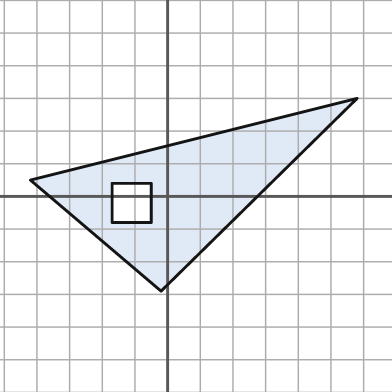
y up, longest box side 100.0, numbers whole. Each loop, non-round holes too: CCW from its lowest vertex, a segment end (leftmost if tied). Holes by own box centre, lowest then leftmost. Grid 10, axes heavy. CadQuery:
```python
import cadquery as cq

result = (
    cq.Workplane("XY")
    .moveTo(-2.0, -29.0)
    .lineTo(58.0, 30.0)
    .lineTo(-42.0, 5.0)
    .close()
    .moveTo(-17.0, -8.0)
    .lineTo(-5.0, -8.0)
    .lineTo(-5.0, 4.0)
    .lineTo(-17.0, 4.0)
    .close()
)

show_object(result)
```